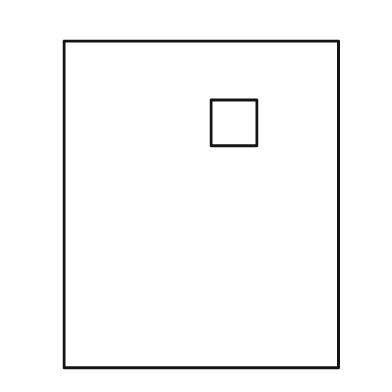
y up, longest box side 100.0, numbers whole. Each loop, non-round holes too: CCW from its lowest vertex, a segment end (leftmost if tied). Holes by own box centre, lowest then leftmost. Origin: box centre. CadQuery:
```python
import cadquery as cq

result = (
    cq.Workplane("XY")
    .moveTo(-42.0, -50.0)
    .lineTo(42.0, -50.0)
    .lineTo(42.0, 50.0)
    .lineTo(-42.0, 50.0)
    .close()
    .moveTo(3.0, 18.0)
    .lineTo(17.0, 18.0)
    .lineTo(17.0, 32.0)
    .lineTo(3.0, 32.0)
    .close()
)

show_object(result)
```